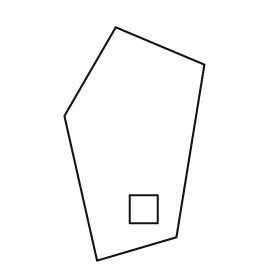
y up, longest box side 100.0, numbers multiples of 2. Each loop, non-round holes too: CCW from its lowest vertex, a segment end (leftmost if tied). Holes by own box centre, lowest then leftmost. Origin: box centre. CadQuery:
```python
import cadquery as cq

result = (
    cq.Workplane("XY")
    .moveTo(-16.0, -50.0)
    .lineTo(18.0, -40.0)
    .lineTo(30.0, 34.0)
    .lineTo(-8.0, 50.0)
    .lineTo(-30.0, 12.0)
    .close()
    .moveTo(-2.0, -34.0)
    .lineTo(10.0, -34.0)
    .lineTo(10.0, -22.0)
    .lineTo(-2.0, -22.0)
    .close()
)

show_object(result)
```